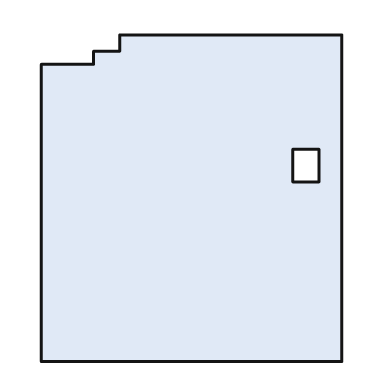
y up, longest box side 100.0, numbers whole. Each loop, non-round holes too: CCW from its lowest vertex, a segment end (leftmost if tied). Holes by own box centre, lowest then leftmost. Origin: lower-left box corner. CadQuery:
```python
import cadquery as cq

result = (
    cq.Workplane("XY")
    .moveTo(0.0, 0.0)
    .lineTo(92.0, 0.0)
    .lineTo(92.0, 100.0)
    .lineTo(24.0, 100.0)
    .lineTo(24.0, 95.0)
    .lineTo(16.0, 95.0)
    .lineTo(16.0, 91.0)
    .lineTo(0.0, 91.0)
    .close()
    .moveTo(77.0, 55.0)
    .lineTo(85.0, 55.0)
    .lineTo(85.0, 65.0)
    .lineTo(77.0, 65.0)
    .close()
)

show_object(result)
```